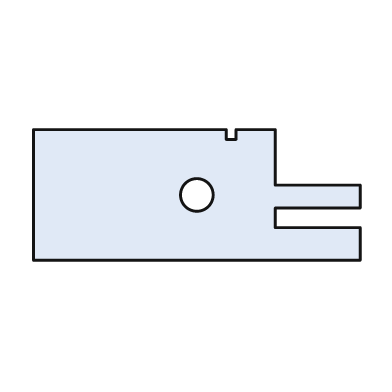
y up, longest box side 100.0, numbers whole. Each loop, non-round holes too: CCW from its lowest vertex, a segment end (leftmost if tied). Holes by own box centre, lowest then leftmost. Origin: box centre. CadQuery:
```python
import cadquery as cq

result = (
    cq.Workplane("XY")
    .moveTo(-50.0, -20.0)
    .lineTo(50.0, -20.0)
    .lineTo(50.0, -10.0)
    .lineTo(24.0, -10.0)
    .lineTo(24.0, -4.0)
    .lineTo(50.0, -4.0)
    .lineTo(50.0, 3.0)
    .lineTo(24.0, 3.0)
    .lineTo(24.0, 20.0)
    .lineTo(12.0, 20.0)
    .lineTo(12.0, 17.0)
    .lineTo(9.0, 17.0)
    .lineTo(9.0, 20.0)
    .lineTo(-50.0, 20.0)
    .close()
    .moveTo(0.0, 0.0)
    .circle(5.0)
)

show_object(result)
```